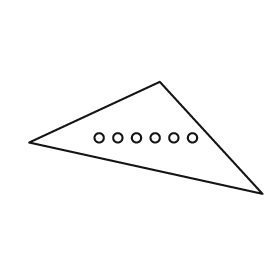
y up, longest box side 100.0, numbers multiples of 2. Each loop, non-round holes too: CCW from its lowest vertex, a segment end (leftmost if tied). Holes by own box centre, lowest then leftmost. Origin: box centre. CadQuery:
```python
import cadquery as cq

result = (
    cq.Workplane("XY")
    .moveTo(50.0, -24.0)
    .lineTo(6.0, 24.0)
    .lineTo(-50.0, -2.0)
    .close()
    .moveTo(-20.0, 0.0)
    .circle(2.0)
    .moveTo(-12.0, 0.0)
    .circle(2.0)
    .moveTo(-4.0, 0.0)
    .circle(2.0)
    .moveTo(4.0, 0.0)
    .circle(2.0)
    .moveTo(12.0, 0.0)
    .circle(2.0)
    .moveTo(20.0, 0.0)
    .circle(2.0)
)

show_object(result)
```